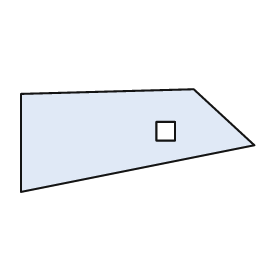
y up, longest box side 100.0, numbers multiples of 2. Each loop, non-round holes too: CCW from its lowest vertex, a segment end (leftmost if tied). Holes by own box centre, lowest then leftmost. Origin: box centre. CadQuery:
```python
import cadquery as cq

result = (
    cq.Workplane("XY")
    .moveTo(-50.0, -22.0)
    .lineTo(50.0, -2.0)
    .lineTo(24.0, 22.0)
    .lineTo(-50.0, 20.0)
    .close()
    .moveTo(8.0, 0.0)
    .lineTo(16.0, 0.0)
    .lineTo(16.0, 8.0)
    .lineTo(8.0, 8.0)
    .close()
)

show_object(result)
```